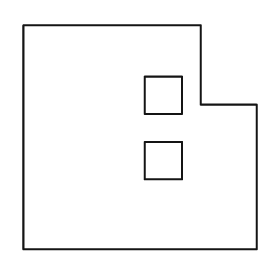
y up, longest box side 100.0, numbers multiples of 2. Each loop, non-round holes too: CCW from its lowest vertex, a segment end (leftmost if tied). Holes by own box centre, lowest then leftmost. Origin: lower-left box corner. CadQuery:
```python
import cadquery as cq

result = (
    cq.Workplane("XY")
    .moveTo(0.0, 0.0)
    .lineTo(100.0, 0.0)
    .lineTo(100.0, 62.0)
    .lineTo(76.0, 62.0)
    .lineTo(76.0, 96.0)
    .lineTo(0.0, 96.0)
    .close()
    .moveTo(52.0, 30.0)
    .lineTo(68.0, 30.0)
    .lineTo(68.0, 46.0)
    .lineTo(52.0, 46.0)
    .close()
    .moveTo(52.0, 58.0)
    .lineTo(68.0, 58.0)
    .lineTo(68.0, 74.0)
    .lineTo(52.0, 74.0)
    .close()
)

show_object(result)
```